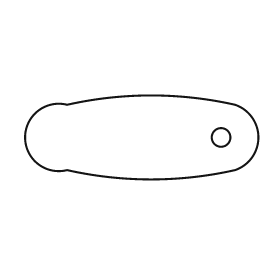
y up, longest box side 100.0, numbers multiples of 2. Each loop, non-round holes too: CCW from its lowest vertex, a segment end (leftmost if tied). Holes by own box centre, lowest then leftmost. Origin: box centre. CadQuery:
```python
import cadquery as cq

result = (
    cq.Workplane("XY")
    .moveTo(-32.0, -14.0)
    .threePointArc((4.0, -18.0), (40.0, -14.0))
    .threePointArc((50.0, 0.0), (40.0, 14.0))
    .threePointArc((4.0, 18.0), (-32.0, 14.0))
    .threePointArc((-50.0, 0.0), (-32.0, -14.0))
    .close()
    .moveTo(34.0, 0.0)
    .circle(4.0)
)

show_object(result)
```